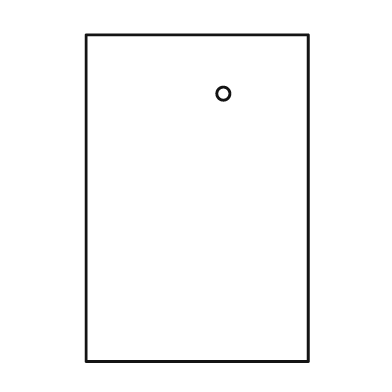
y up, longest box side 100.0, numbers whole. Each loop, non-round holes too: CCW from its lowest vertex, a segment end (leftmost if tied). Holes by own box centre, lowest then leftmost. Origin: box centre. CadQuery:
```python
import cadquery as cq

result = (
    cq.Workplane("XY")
    .moveTo(-34.0, -50.0)
    .lineTo(34.0, -50.0)
    .lineTo(34.0, 50.0)
    .lineTo(-34.0, 50.0)
    .close()
    .moveTo(8.0, 32.0)
    .circle(2.0)
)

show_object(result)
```